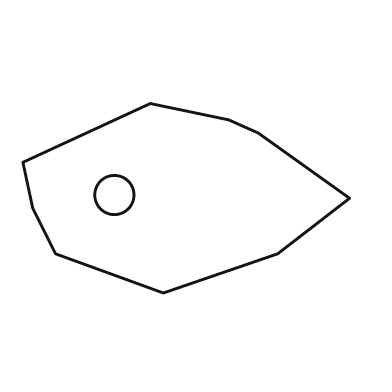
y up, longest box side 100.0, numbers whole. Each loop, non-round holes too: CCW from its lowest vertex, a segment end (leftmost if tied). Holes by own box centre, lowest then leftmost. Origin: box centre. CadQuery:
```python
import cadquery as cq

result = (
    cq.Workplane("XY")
    .moveTo(-7.0, -29.0)
    .lineTo(28.0, -17.0)
    .lineTo(50.0, 0.0)
    .lineTo(22.0, 20.0)
    .lineTo(13.0, 24.0)
    .lineTo(-11.0, 29.0)
    .lineTo(-50.0, 11.0)
    .lineTo(-47.0, -3.0)
    .lineTo(-40.0, -17.0)
    .close()
    .moveTo(-22.0, 1.0)
    .circle(6.0)
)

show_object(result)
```